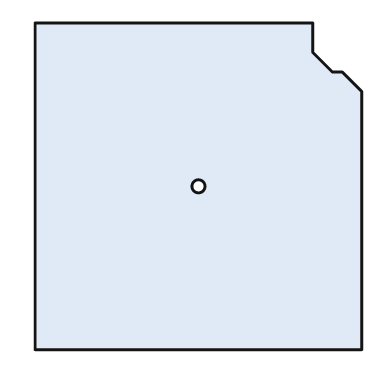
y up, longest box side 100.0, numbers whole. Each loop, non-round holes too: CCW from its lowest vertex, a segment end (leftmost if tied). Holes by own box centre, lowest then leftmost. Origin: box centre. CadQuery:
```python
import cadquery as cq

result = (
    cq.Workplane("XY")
    .moveTo(-50.0, -50.0)
    .lineTo(50.0, -50.0)
    .lineTo(50.0, 29.0)
    .lineTo(44.0, 35.0)
    .lineTo(41.0, 35.0)
    .lineTo(35.0, 41.0)
    .lineTo(35.0, 50.0)
    .lineTo(-50.0, 50.0)
    .close()
    .moveTo(0.0, 0.0)
    .circle(2.0)
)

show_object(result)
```